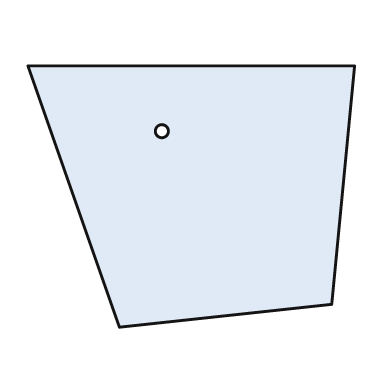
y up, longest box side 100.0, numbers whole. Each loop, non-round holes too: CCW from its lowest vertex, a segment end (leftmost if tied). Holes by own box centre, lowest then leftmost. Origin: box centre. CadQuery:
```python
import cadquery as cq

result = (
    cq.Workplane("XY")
    .moveTo(-22.0, -40.0)
    .lineTo(43.0, -33.0)
    .lineTo(50.0, 40.0)
    .lineTo(-50.0, 40.0)
    .close()
    .moveTo(-9.0, 20.0)
    .circle(2.0)
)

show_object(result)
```